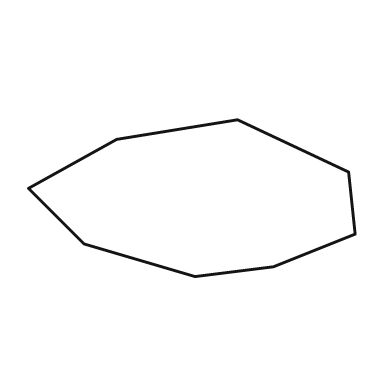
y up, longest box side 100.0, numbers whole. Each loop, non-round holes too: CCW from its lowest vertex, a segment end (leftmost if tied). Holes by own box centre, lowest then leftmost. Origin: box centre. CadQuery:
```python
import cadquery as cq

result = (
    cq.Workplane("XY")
    .moveTo(1.0, -24.0)
    .lineTo(25.0, -21.0)
    .lineTo(50.0, -11.0)
    .lineTo(48.0, 8.0)
    .lineTo(14.0, 24.0)
    .lineTo(-23.0, 18.0)
    .lineTo(-50.0, 3.0)
    .lineTo(-33.0, -14.0)
    .close()
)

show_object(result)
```